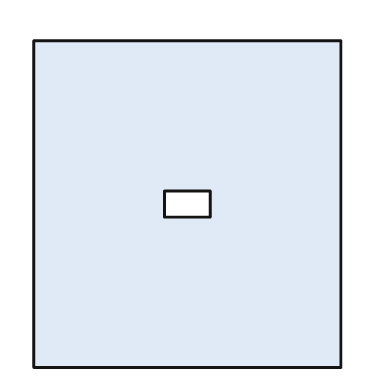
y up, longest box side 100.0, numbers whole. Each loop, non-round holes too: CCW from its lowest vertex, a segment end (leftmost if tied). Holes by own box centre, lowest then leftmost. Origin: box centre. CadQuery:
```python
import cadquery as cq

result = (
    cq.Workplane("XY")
    .moveTo(-47.0, -50.0)
    .lineTo(47.0, -50.0)
    .lineTo(47.0, 50.0)
    .lineTo(-47.0, 50.0)
    .close()
    .moveTo(-7.0, -4.0)
    .lineTo(7.0, -4.0)
    .lineTo(7.0, 4.0)
    .lineTo(-7.0, 4.0)
    .close()
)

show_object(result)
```